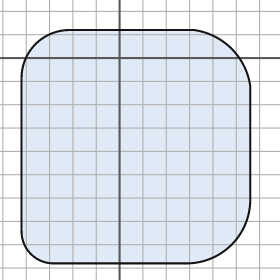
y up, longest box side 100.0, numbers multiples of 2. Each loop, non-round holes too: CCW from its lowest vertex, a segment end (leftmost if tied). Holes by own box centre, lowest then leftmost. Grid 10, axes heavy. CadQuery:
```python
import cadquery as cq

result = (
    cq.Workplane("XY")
    .moveTo(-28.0, -88.0)
    .lineTo(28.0, -88.0)
    .threePointArc((48.0, -80.0), (56.0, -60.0))
    .lineTo(56.0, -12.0)
    .threePointArc((48.0, 4.0), (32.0, 12.0))
    .lineTo(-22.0, 12.0)
    .threePointArc((-36.0, 6.0), (-42.0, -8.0))
    .lineTo(-42.0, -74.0)
    .threePointArc((-38.0, -84.0), (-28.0, -88.0))
    .close()
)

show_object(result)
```